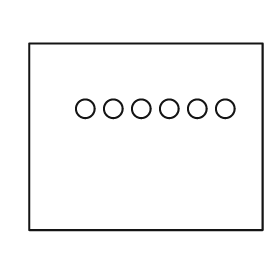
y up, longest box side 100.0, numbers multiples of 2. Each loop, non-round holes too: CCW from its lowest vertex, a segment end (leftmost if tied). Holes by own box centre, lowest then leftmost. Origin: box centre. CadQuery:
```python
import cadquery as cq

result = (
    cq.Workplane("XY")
    .moveTo(-50.0, -40.0)
    .lineTo(50.0, -40.0)
    .lineTo(50.0, 40.0)
    .lineTo(-50.0, 40.0)
    .close()
    .moveTo(-26.0, 12.0)
    .circle(4.0)
    .moveTo(-14.0, 12.0)
    .circle(4.0)
    .moveTo(-2.0, 12.0)
    .circle(4.0)
    .moveTo(10.0, 12.0)
    .circle(4.0)
    .moveTo(22.0, 12.0)
    .circle(4.0)
    .moveTo(34.0, 12.0)
    .circle(4.0)
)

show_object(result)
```